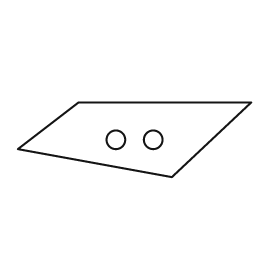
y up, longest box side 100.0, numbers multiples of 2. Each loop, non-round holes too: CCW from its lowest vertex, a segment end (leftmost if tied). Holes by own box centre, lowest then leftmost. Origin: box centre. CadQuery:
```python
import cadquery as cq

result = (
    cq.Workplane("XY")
    .moveTo(16.0, -16.0)
    .lineTo(50.0, 16.0)
    .lineTo(-24.0, 16.0)
    .lineTo(-50.0, -4.0)
    .close()
    .moveTo(-8.0, 0.0)
    .circle(4.0)
    .moveTo(8.0, 0.0)
    .circle(4.0)
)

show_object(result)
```